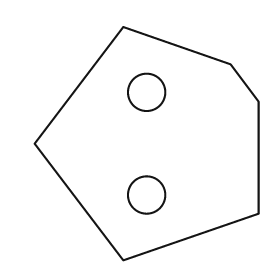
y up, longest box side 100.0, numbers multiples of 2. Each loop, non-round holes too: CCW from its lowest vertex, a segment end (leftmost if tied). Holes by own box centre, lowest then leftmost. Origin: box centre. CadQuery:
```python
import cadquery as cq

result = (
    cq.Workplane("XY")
    .moveTo(-10.0, -50.0)
    .lineTo(48.0, -30.0)
    .lineTo(48.0, 18.0)
    .lineTo(36.0, 34.0)
    .lineTo(-10.0, 50.0)
    .lineTo(-48.0, 0.0)
    .close()
    .moveTo(0.0, -22.0)
    .circle(8.0)
    .moveTo(0.0, 22.0)
    .circle(8.0)
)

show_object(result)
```